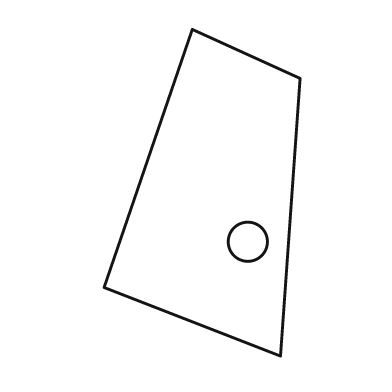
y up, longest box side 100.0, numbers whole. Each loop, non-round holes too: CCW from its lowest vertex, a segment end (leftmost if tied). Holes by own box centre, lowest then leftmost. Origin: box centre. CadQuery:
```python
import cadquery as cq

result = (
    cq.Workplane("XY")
    .moveTo(24.0, -50.0)
    .lineTo(30.0, 35.0)
    .lineTo(-3.0, 50.0)
    .lineTo(-30.0, -29.0)
    .close()
    .moveTo(14.0, -15.0)
    .circle(6.0)
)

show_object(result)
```